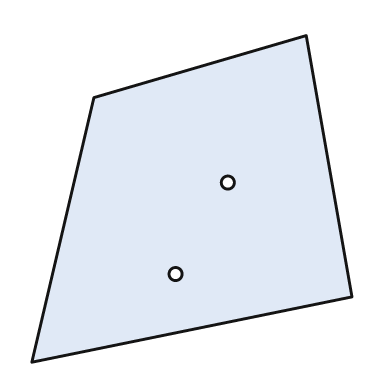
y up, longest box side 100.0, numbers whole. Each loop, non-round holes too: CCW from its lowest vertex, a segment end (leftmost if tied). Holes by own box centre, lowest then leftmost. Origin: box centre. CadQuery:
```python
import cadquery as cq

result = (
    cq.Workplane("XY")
    .moveTo(-49.0, -50.0)
    .lineTo(49.0, -30.0)
    .lineTo(35.0, 50.0)
    .lineTo(-30.0, 31.0)
    .close()
    .moveTo(-5.0, -23.0)
    .circle(2.0)
    .moveTo(11.0, 5.0)
    .circle(2.0)
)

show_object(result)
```